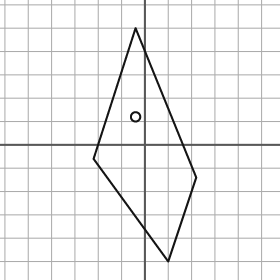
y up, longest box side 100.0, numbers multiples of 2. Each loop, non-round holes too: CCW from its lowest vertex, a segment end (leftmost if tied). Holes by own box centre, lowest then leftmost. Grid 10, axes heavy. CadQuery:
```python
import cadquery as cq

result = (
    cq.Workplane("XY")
    .moveTo(10.0, -50.0)
    .lineTo(22.0, -14.0)
    .lineTo(-4.0, 50.0)
    .lineTo(-22.0, -6.0)
    .close()
    .moveTo(-4.0, 12.0)
    .circle(2.0)
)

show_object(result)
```